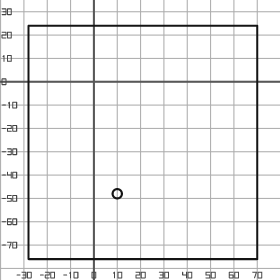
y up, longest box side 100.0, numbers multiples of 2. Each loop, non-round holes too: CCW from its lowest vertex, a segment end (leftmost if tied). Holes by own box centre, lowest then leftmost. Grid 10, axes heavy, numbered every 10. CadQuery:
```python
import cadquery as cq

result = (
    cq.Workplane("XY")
    .moveTo(-28.0, -76.0)
    .lineTo(70.0, -76.0)
    .lineTo(70.0, 24.0)
    .lineTo(-28.0, 24.0)
    .close()
    .moveTo(10.0, -48.0)
    .circle(2.0)
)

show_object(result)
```